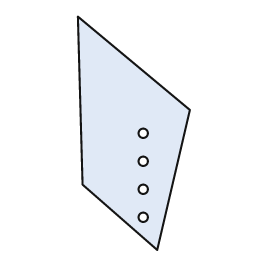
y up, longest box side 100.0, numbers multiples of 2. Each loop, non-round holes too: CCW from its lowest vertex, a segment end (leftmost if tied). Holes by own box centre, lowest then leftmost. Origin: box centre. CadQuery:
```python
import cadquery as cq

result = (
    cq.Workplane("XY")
    .moveTo(10.0, -50.0)
    .lineTo(24.0, 10.0)
    .lineTo(-24.0, 50.0)
    .lineTo(-22.0, -22.0)
    .close()
    .moveTo(4.0, -36.0)
    .circle(2.0)
    .moveTo(4.0, -24.0)
    .circle(2.0)
    .moveTo(4.0, -12.0)
    .circle(2.0)
    .moveTo(4.0, 0.0)
    .circle(2.0)
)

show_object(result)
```